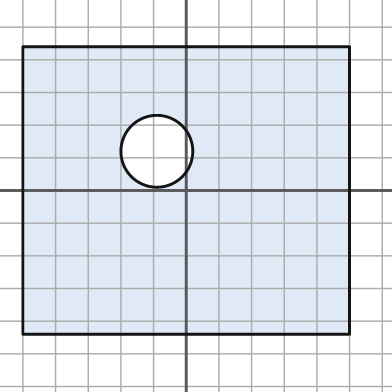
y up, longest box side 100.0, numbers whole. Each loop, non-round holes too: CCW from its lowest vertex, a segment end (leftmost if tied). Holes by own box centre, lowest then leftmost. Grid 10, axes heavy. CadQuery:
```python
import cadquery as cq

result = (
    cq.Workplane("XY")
    .moveTo(-50.0, -44.0)
    .lineTo(50.0, -44.0)
    .lineTo(50.0, 44.0)
    .lineTo(-50.0, 44.0)
    .close()
    .moveTo(-9.0, 12.0)
    .circle(11.0)
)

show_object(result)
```